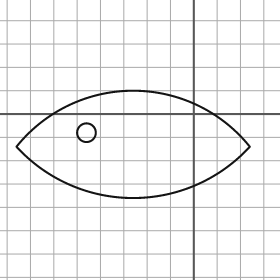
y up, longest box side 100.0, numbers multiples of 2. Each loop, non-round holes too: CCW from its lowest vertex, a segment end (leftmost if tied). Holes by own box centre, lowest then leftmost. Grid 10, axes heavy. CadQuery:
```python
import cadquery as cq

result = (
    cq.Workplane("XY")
    .moveTo(-76.0, -14.0)
    .threePointArc((-26.0, -36.0), (24.0, -14.0))
    .threePointArc((-26.0, 10.0), (-76.0, -14.0))
    .close()
    .moveTo(-46.0, -8.0)
    .circle(4.0)
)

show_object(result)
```